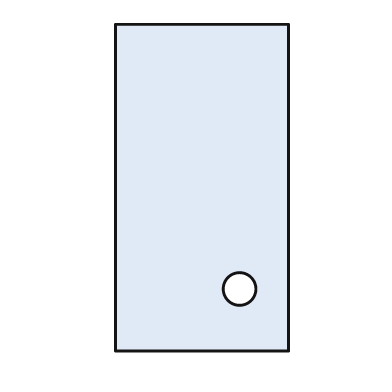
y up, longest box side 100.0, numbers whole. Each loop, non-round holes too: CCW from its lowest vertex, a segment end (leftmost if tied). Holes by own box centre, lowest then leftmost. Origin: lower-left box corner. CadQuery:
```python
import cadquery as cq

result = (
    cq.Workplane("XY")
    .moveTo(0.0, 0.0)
    .lineTo(53.0, 0.0)
    .lineTo(53.0, 100.0)
    .lineTo(0.0, 100.0)
    .close()
    .moveTo(38.0, 19.0)
    .circle(5.0)
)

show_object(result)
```